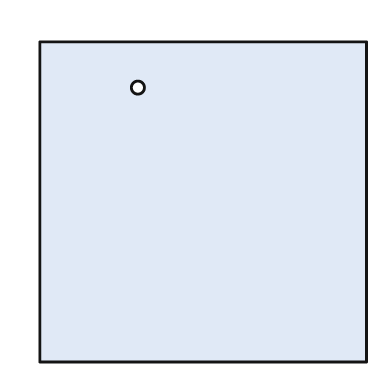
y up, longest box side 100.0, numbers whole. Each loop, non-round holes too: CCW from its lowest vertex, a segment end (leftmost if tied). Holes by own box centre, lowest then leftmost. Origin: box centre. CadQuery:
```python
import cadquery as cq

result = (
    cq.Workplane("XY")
    .moveTo(-50.0, -49.0)
    .lineTo(50.0, -49.0)
    .lineTo(50.0, 49.0)
    .lineTo(-50.0, 49.0)
    .close()
    .moveTo(-20.0, 35.0)
    .circle(2.0)
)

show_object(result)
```